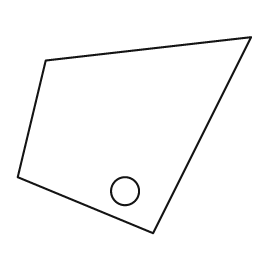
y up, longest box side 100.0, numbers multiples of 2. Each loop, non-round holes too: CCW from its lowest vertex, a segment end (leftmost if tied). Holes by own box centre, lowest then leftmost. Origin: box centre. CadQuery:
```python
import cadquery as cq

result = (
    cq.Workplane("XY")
    .moveTo(8.0, -42.0)
    .lineTo(50.0, 42.0)
    .lineTo(-38.0, 32.0)
    .lineTo(-50.0, -18.0)
    .close()
    .moveTo(-4.0, -24.0)
    .circle(6.0)
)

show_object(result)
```